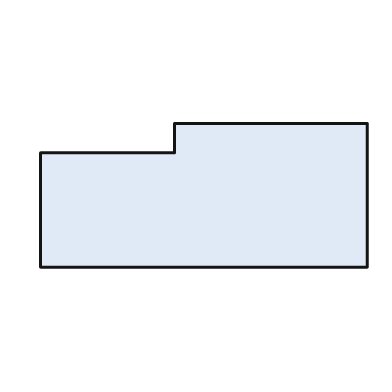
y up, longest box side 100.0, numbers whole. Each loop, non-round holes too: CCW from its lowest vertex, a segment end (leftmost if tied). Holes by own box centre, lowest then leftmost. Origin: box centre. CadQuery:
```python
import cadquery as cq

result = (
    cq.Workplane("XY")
    .moveTo(-50.0, -22.0)
    .lineTo(50.0, -22.0)
    .lineTo(50.0, 22.0)
    .lineTo(-9.0, 22.0)
    .lineTo(-9.0, 13.0)
    .lineTo(-50.0, 13.0)
    .close()
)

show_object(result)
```